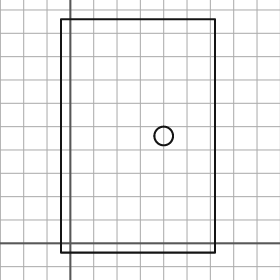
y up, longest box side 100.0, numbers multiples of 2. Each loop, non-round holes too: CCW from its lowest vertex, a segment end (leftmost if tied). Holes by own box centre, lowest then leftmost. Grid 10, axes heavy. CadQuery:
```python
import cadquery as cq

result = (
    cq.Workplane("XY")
    .moveTo(-4.0, -4.0)
    .lineTo(62.0, -4.0)
    .lineTo(62.0, 96.0)
    .lineTo(-4.0, 96.0)
    .close()
    .moveTo(40.0, 46.0)
    .circle(4.0)
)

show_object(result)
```